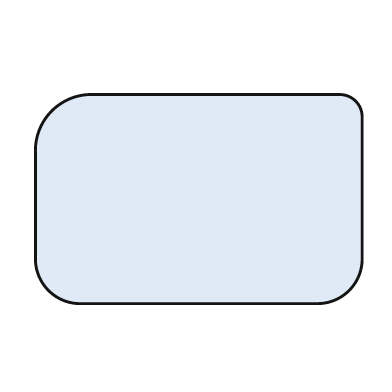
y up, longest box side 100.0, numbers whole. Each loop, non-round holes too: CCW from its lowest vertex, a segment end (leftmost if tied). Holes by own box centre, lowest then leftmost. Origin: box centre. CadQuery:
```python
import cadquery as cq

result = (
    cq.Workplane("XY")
    .moveTo(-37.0, -32.0)
    .lineTo(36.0, -32.0)
    .threePointArc((46.0, -28.0), (50.0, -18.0))
    .lineTo(50.0, 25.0)
    .threePointArc((48.0, 30.0), (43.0, 32.0))
    .lineTo(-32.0, 32.0)
    .threePointArc((-45.0, 27.0), (-50.0, 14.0))
    .lineTo(-50.0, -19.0)
    .threePointArc((-46.0, -28.0), (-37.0, -32.0))
    .close()
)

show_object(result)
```